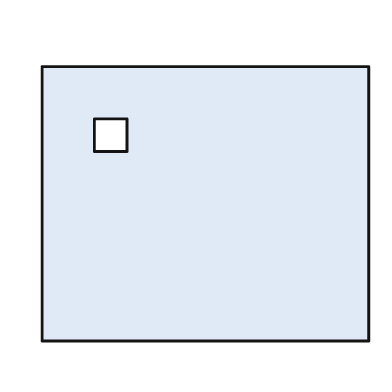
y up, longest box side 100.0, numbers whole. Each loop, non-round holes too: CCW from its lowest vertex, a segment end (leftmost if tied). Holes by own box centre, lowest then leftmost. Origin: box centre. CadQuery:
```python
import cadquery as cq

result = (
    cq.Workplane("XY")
    .moveTo(-50.0, -42.0)
    .lineTo(50.0, -42.0)
    .lineTo(50.0, 42.0)
    .lineTo(-50.0, 42.0)
    .close()
    .moveTo(-34.0, 16.0)
    .lineTo(-24.0, 16.0)
    .lineTo(-24.0, 26.0)
    .lineTo(-34.0, 26.0)
    .close()
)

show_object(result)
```